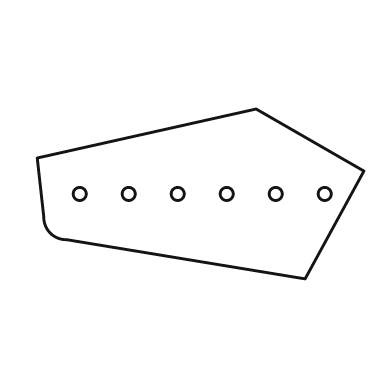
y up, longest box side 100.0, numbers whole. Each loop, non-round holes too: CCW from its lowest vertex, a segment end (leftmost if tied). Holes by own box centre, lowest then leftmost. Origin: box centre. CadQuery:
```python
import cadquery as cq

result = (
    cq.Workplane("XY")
    .moveTo(32.0, -26.0)
    .lineTo(50.0, 7.0)
    .lineTo(17.0, 26.0)
    .lineTo(-50.0, 11.0)
    .lineTo(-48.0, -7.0)
    .threePointArc((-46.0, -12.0), (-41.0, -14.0))
    .close()
    .moveTo(-37.0, 0.0)
    .circle(2.0)
    .moveTo(-22.0, 0.0)
    .circle(2.0)
    .moveTo(-7.0, 0.0)
    .circle(2.0)
    .moveTo(8.0, 0.0)
    .circle(2.0)
    .moveTo(23.0, 0.0)
    .circle(2.0)
    .moveTo(38.0, 0.0)
    .circle(2.0)
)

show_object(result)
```